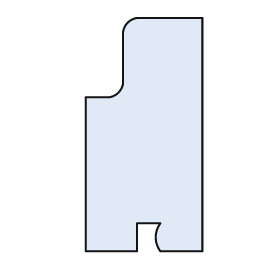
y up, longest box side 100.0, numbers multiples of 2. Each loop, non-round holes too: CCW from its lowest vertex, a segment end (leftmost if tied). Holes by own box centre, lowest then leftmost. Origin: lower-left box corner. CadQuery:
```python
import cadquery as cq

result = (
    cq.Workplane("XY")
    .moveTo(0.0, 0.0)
    .lineTo(22.0, 0.0)
    .lineTo(22.0, 12.0)
    .lineTo(32.0, 12.0)
    .threePointArc((30.0, 6.0), (32.0, 0.0))
    .lineTo(50.0, 0.0)
    .lineTo(50.0, 100.0)
    .lineTo(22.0, 100.0)
    .threePointArc((18.0, 98.0), (16.0, 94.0))
    .lineTo(16.0, 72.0)
    .threePointArc((14.0, 68.0), (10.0, 66.0))
    .lineTo(0.0, 66.0)
    .close()
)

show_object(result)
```